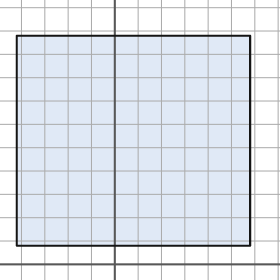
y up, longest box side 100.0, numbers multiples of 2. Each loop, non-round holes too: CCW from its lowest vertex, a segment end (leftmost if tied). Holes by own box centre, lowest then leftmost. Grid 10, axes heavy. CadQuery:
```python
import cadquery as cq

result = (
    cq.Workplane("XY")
    .moveTo(-42.0, 8.0)
    .lineTo(58.0, 8.0)
    .lineTo(58.0, 98.0)
    .lineTo(-42.0, 98.0)
    .close()
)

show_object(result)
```